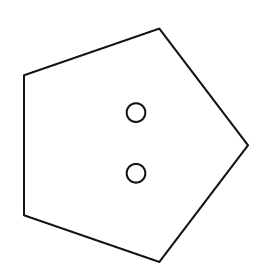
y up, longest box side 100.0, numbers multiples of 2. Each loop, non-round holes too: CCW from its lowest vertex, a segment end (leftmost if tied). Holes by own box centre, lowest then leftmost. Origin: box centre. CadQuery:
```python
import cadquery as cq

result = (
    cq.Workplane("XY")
    .moveTo(10.0, -50.0)
    .lineTo(48.0, 0.0)
    .lineTo(10.0, 50.0)
    .lineTo(-48.0, 30.0)
    .lineTo(-48.0, -30.0)
    .close()
    .moveTo(0.0, -12.0)
    .circle(4.0)
    .moveTo(0.0, 14.0)
    .circle(4.0)
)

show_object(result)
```